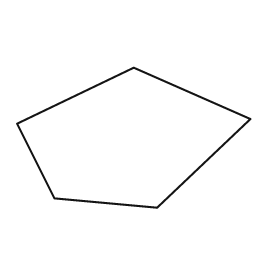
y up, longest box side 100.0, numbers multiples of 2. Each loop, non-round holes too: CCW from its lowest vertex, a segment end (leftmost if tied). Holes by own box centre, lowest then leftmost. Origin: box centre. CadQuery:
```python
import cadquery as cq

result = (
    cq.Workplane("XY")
    .moveTo(10.0, -30.0)
    .lineTo(50.0, 8.0)
    .lineTo(0.0, 30.0)
    .lineTo(-50.0, 6.0)
    .lineTo(-34.0, -26.0)
    .close()
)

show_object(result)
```